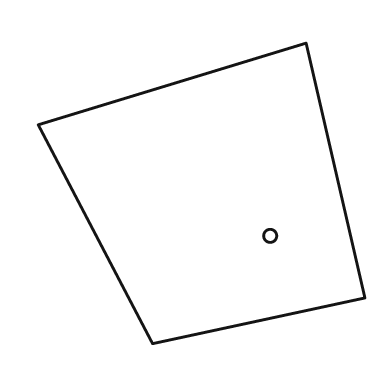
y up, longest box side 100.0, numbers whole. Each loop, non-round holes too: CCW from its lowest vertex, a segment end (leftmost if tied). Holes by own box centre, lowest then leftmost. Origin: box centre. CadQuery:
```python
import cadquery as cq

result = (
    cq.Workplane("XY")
    .moveTo(-15.0, -46.0)
    .lineTo(50.0, -32.0)
    .lineTo(32.0, 46.0)
    .lineTo(-50.0, 21.0)
    .close()
    .moveTo(21.0, -13.0)
    .circle(2.0)
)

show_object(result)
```